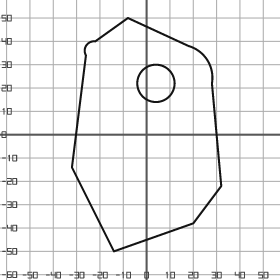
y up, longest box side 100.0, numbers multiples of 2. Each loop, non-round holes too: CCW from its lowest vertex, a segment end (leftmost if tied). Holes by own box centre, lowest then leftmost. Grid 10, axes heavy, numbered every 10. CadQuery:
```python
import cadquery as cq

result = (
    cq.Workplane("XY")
    .moveTo(-14.0, -50.0)
    .lineTo(20.0, -38.0)
    .lineTo(32.0, -22.0)
    .lineTo(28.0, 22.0)
    .threePointArc((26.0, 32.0), (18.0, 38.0))
    .lineTo(-8.0, 50.0)
    .lineTo(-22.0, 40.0)
    .threePointArc((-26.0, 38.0), (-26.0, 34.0))
    .lineTo(-32.0, -14.0)
    .close()
    .moveTo(4.0, 22.0)
    .circle(8.0)
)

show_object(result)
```